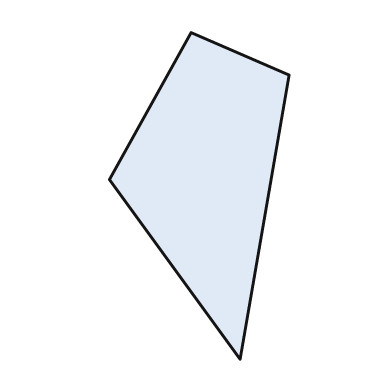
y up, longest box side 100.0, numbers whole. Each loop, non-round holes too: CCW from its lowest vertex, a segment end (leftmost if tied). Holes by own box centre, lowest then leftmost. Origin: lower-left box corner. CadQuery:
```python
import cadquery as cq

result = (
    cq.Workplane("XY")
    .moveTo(40.0, 0.0)
    .lineTo(55.0, 87.0)
    .lineTo(25.0, 100.0)
    .lineTo(0.0, 55.0)
    .close()
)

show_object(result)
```